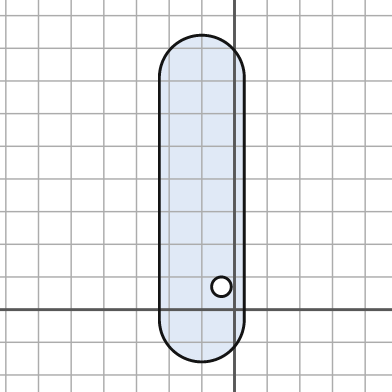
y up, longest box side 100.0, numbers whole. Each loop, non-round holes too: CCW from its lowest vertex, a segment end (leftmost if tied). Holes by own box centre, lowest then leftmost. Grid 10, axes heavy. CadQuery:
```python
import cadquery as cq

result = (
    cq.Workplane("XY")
    .moveTo(-23.0, -3.0)
    .threePointArc((-10.0, -16.0), (3.0, -3.0))
    .lineTo(3.0, 71.0)
    .threePointArc((-10.0, 84.0), (-23.0, 71.0))
    .close()
    .moveTo(-4.0, 7.0)
    .circle(3.0)
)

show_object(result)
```